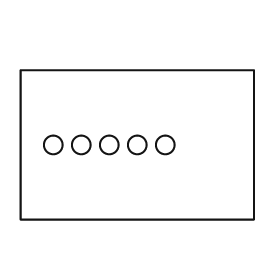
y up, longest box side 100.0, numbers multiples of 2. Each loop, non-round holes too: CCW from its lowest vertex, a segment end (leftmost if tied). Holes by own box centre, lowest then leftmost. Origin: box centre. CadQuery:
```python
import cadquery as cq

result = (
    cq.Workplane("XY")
    .moveTo(-50.0, -32.0)
    .lineTo(50.0, -32.0)
    .lineTo(50.0, 32.0)
    .lineTo(-50.0, 32.0)
    .close()
    .moveTo(-36.0, 0.0)
    .circle(4.0)
    .moveTo(-24.0, 0.0)
    .circle(4.0)
    .moveTo(-12.0, 0.0)
    .circle(4.0)
    .moveTo(0.0, 0.0)
    .circle(4.0)
    .moveTo(12.0, 0.0)
    .circle(4.0)
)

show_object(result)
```